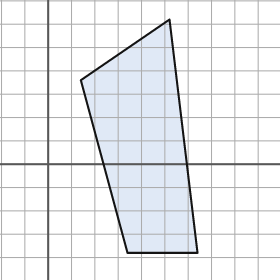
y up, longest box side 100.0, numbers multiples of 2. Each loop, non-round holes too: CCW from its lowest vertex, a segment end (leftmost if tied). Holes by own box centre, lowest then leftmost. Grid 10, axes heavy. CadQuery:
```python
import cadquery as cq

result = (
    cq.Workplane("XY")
    .moveTo(34.0, -38.0)
    .lineTo(64.0, -38.0)
    .lineTo(52.0, 62.0)
    .lineTo(14.0, 36.0)
    .close()
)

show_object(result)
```